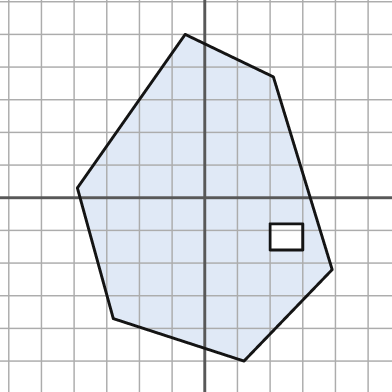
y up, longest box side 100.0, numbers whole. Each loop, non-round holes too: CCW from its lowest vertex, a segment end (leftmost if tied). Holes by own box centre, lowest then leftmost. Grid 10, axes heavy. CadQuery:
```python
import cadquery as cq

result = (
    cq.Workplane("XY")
    .moveTo(12.0, -50.0)
    .lineTo(39.0, -22.0)
    .lineTo(21.0, 37.0)
    .lineTo(-6.0, 50.0)
    .lineTo(-39.0, 3.0)
    .lineTo(-28.0, -37.0)
    .close()
    .moveTo(20.0, -16.0)
    .lineTo(30.0, -16.0)
    .lineTo(30.0, -8.0)
    .lineTo(20.0, -8.0)
    .close()
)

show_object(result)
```